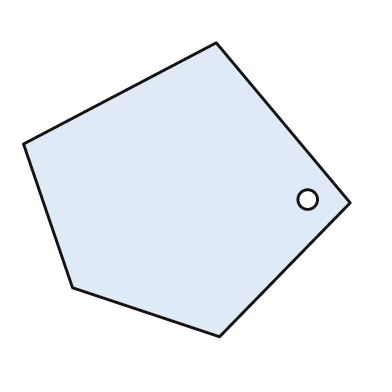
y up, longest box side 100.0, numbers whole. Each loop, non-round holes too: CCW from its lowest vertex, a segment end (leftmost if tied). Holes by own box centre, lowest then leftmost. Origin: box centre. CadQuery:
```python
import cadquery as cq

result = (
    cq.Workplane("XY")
    .moveTo(10.0, -45.0)
    .lineTo(50.0, -4.0)
    .lineTo(9.0, 45.0)
    .lineTo(-50.0, 14.0)
    .lineTo(-35.0, -30.0)
    .close()
    .moveTo(37.0, -3.0)
    .circle(3.0)
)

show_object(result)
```